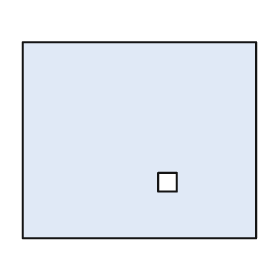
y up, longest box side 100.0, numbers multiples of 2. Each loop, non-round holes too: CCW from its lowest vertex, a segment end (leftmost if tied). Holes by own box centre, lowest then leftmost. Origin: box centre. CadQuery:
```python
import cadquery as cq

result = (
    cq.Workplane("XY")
    .moveTo(-50.0, -42.0)
    .lineTo(50.0, -42.0)
    .lineTo(50.0, 42.0)
    .lineTo(-50.0, 42.0)
    .close()
    .moveTo(8.0, -22.0)
    .lineTo(16.0, -22.0)
    .lineTo(16.0, -14.0)
    .lineTo(8.0, -14.0)
    .close()
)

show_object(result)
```